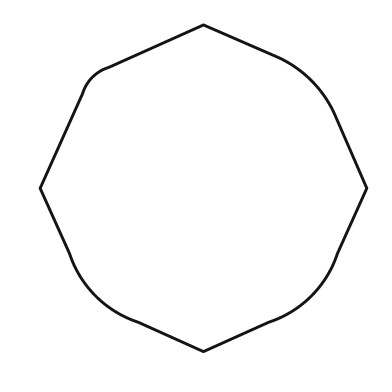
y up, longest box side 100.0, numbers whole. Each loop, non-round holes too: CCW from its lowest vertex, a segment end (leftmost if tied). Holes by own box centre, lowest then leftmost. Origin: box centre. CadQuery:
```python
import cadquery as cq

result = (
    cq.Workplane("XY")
    .moveTo(0.0, -50.0)
    .lineTo(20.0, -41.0)
    .threePointArc((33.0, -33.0), (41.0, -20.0))
    .lineTo(50.0, 0.0)
    .lineTo(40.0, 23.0)
    .threePointArc((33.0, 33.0), (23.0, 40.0))
    .lineTo(0.0, 50.0)
    .lineTo(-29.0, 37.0)
    .threePointArc((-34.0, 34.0), (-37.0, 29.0))
    .lineTo(-50.0, 0.0)
    .lineTo(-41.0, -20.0)
    .threePointArc((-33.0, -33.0), (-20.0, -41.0))
    .close()
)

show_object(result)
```